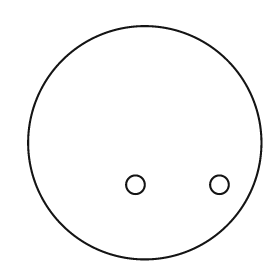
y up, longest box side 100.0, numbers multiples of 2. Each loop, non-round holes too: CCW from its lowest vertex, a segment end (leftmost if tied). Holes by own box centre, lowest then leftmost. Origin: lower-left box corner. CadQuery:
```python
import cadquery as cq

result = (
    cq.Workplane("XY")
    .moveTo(50.0, 50.0)
    .circle(50.0)
    .moveTo(46.0, 32.0)
    .circle(4.0)
    .moveTo(82.0, 32.0)
    .circle(4.0)
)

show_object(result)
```